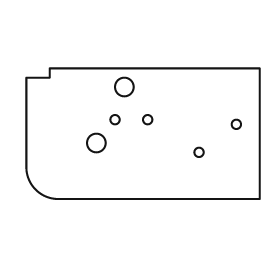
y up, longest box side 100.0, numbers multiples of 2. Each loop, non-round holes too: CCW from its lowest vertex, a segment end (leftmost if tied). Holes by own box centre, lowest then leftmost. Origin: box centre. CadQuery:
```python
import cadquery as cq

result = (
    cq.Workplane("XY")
    .moveTo(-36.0, -28.0)
    .lineTo(50.0, -28.0)
    .lineTo(50.0, 28.0)
    .lineTo(-40.0, 28.0)
    .lineTo(-40.0, 24.0)
    .lineTo(-50.0, 24.0)
    .lineTo(-50.0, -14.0)
    .threePointArc((-46.0, -24.0), (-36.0, -28.0))
    .close()
    .moveTo(24.0, -8.0)
    .circle(2.0)
    .moveTo(-20.0, -4.0)
    .circle(4.0)
    .moveTo(40.0, 4.0)
    .circle(2.0)
    .moveTo(-12.0, 6.0)
    .circle(2.0)
    .moveTo(2.0, 6.0)
    .circle(2.0)
    .moveTo(-8.0, 20.0)
    .circle(4.0)
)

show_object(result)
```